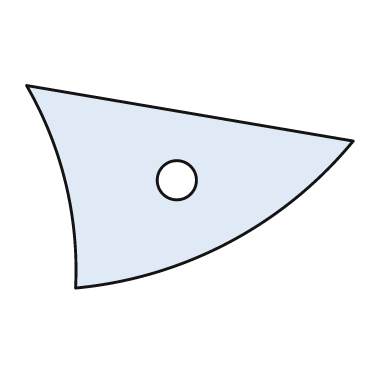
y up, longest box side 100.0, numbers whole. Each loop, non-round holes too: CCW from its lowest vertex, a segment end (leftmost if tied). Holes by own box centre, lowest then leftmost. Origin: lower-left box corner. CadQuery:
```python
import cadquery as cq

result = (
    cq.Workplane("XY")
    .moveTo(15.0, 0.0)
    .threePointArc((62.0, 14.0), (100.0, 45.0))
    .lineTo(0.0, 62.0)
    .threePointArc((12.0, 32.0), (15.0, 0.0))
    .close()
    .moveTo(46.0, 33.0)
    .circle(6.0)
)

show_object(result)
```